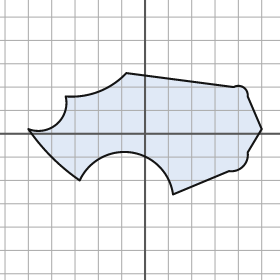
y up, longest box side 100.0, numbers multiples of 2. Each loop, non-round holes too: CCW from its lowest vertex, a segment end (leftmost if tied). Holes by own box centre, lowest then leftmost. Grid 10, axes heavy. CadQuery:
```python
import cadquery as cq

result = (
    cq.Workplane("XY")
    .moveTo(12.0, -26.0)
    .lineTo(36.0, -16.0)
    .threePointArc((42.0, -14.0), (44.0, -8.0))
    .lineTo(50.0, 2.0)
    .lineTo(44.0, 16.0)
    .threePointArc((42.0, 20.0), (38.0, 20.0))
    .lineTo(-8.0, 26.0)
    .threePointArc((-20.0, 18.0), (-34.0, 16.0))
    .threePointArc((-38.0, 4.0), (-50.0, 2.0))
    .threePointArc((-40.0, -10.0), (-28.0, -20.0))
    .threePointArc((-6.0, -8.0), (12.0, -26.0))
    .close()
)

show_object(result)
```